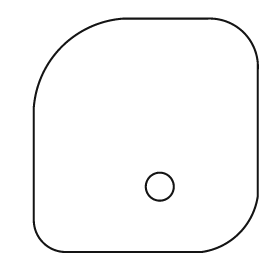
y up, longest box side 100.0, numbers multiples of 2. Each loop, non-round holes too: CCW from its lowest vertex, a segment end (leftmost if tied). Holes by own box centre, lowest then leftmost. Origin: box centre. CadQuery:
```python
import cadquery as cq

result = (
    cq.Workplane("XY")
    .moveTo(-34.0, -50.0)
    .lineTo(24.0, -50.0)
    .threePointArc((40.0, -42.0), (48.0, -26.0))
    .lineTo(48.0, 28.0)
    .threePointArc((42.0, 44.0), (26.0, 50.0))
    .lineTo(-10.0, 50.0)
    .threePointArc((-36.0, 38.0), (-48.0, 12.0))
    .lineTo(-48.0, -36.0)
    .threePointArc((-44.0, -46.0), (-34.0, -50.0))
    .close()
    .moveTo(6.0, -22.0)
    .circle(6.0)
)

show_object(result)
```